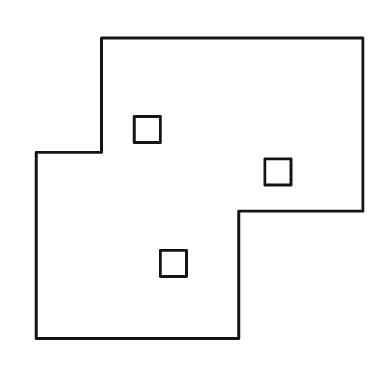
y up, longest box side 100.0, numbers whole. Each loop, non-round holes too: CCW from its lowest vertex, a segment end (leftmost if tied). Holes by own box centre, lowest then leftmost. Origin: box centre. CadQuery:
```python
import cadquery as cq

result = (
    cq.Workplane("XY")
    .moveTo(-50.0, -46.0)
    .lineTo(12.0, -46.0)
    .lineTo(12.0, -7.0)
    .lineTo(50.0, -7.0)
    .lineTo(50.0, 46.0)
    .lineTo(-30.0, 46.0)
    .lineTo(-30.0, 11.0)
    .lineTo(-50.0, 11.0)
    .close()
    .moveTo(-12.0, -27.0)
    .lineTo(-4.0, -27.0)
    .lineTo(-4.0, -19.0)
    .lineTo(-12.0, -19.0)
    .close()
    .moveTo(20.0, 1.0)
    .lineTo(28.0, 1.0)
    .lineTo(28.0, 9.0)
    .lineTo(20.0, 9.0)
    .close()
    .moveTo(-20.0, 14.0)
    .lineTo(-12.0, 14.0)
    .lineTo(-12.0, 22.0)
    .lineTo(-20.0, 22.0)
    .close()
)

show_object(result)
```